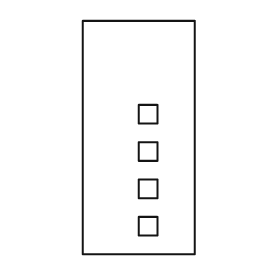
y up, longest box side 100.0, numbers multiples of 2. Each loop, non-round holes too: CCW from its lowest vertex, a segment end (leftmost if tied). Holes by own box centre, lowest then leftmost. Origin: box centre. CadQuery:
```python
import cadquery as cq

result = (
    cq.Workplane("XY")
    .moveTo(-24.0, -50.0)
    .lineTo(24.0, -50.0)
    .lineTo(24.0, 50.0)
    .lineTo(-24.0, 50.0)
    .close()
    .moveTo(0.0, -42.0)
    .lineTo(8.0, -42.0)
    .lineTo(8.0, -34.0)
    .lineTo(0.0, -34.0)
    .close()
    .moveTo(0.0, -26.0)
    .lineTo(8.0, -26.0)
    .lineTo(8.0, -18.0)
    .lineTo(0.0, -18.0)
    .close()
    .moveTo(0.0, -10.0)
    .lineTo(8.0, -10.0)
    .lineTo(8.0, -2.0)
    .lineTo(0.0, -2.0)
    .close()
    .moveTo(0.0, 6.0)
    .lineTo(8.0, 6.0)
    .lineTo(8.0, 14.0)
    .lineTo(0.0, 14.0)
    .close()
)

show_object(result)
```